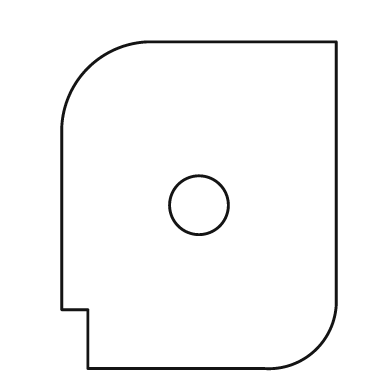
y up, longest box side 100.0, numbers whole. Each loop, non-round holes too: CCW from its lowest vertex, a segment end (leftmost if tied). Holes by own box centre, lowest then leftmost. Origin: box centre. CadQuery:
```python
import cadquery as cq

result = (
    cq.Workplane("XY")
    .moveTo(-34.0, -50.0)
    .lineTo(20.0, -50.0)
    .threePointArc((36.0, -44.0), (42.0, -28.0))
    .lineTo(42.0, 50.0)
    .lineTo(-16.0, 50.0)
    .threePointArc((-34.0, 42.0), (-42.0, 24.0))
    .lineTo(-42.0, -32.0)
    .lineTo(-34.0, -32.0)
    .close()
    .moveTo(0.0, 0.0)
    .circle(9.0)
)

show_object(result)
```